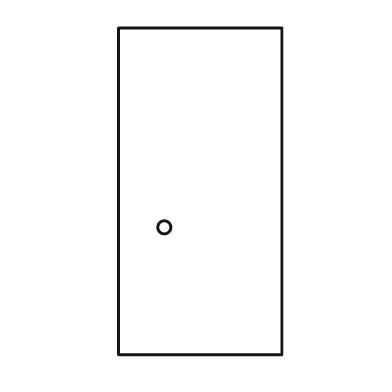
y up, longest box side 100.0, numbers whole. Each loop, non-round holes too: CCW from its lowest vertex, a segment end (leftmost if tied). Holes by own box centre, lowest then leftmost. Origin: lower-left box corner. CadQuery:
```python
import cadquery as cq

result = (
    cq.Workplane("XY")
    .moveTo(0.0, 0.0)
    .lineTo(50.0, 0.0)
    .lineTo(50.0, 100.0)
    .lineTo(0.0, 100.0)
    .close()
    .moveTo(14.0, 39.0)
    .circle(2.0)
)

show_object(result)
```